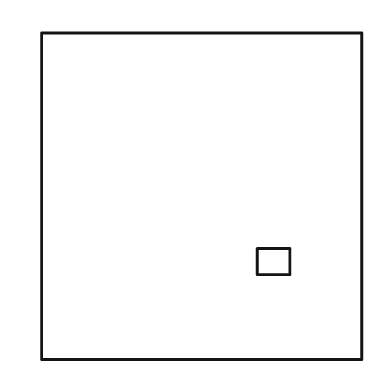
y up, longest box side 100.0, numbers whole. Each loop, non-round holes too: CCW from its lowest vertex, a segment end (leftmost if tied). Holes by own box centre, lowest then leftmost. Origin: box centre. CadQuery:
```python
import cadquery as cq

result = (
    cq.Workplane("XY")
    .moveTo(-49.0, -50.0)
    .lineTo(49.0, -50.0)
    .lineTo(49.0, 50.0)
    .lineTo(-49.0, 50.0)
    .close()
    .moveTo(17.0, -24.0)
    .lineTo(27.0, -24.0)
    .lineTo(27.0, -16.0)
    .lineTo(17.0, -16.0)
    .close()
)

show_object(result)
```